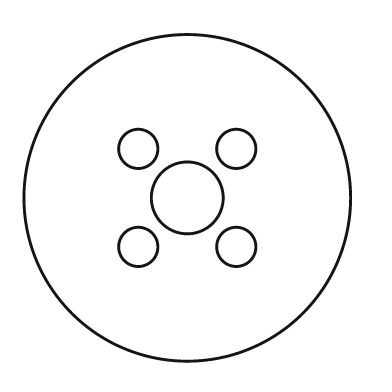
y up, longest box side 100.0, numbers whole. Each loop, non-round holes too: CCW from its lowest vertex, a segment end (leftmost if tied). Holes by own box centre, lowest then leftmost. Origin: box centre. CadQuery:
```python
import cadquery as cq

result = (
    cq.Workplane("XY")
    .moveTo(0.0, 0.0)
    .circle(50.0)
    .moveTo(-15.0, -15.0)
    .circle(6.0)
    .moveTo(15.0, -15.0)
    .circle(6.0)
    .moveTo(0.0, 0.0)
    .circle(11.0)
    .moveTo(-15.0, 15.0)
    .circle(6.0)
    .moveTo(15.0, 15.0)
    .circle(6.0)
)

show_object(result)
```